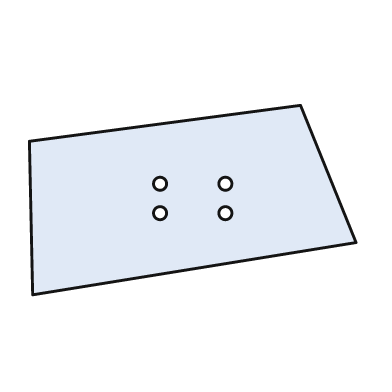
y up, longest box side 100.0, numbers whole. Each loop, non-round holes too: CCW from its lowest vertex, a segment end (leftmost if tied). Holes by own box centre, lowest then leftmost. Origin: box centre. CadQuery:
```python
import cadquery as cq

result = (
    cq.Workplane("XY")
    .moveTo(-49.0, -29.0)
    .lineTo(50.0, -13.0)
    .lineTo(33.0, 29.0)
    .lineTo(-50.0, 18.0)
    .close()
    .moveTo(-10.0, -4.0)
    .circle(2.0)
    .moveTo(10.0, -4.0)
    .circle(2.0)
    .moveTo(-10.0, 5.0)
    .circle(2.0)
    .moveTo(10.0, 5.0)
    .circle(2.0)
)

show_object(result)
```